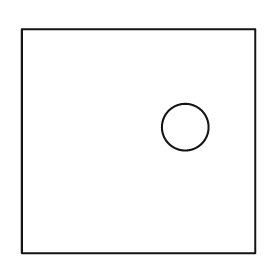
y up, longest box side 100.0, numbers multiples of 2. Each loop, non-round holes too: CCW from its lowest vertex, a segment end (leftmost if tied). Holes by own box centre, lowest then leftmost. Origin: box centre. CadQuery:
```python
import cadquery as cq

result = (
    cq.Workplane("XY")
    .moveTo(-50.0, -48.0)
    .lineTo(50.0, -48.0)
    .lineTo(50.0, 48.0)
    .lineTo(-50.0, 48.0)
    .close()
    .moveTo(20.0, 6.0)
    .circle(10.0)
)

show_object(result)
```